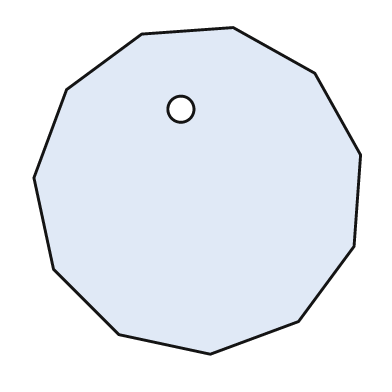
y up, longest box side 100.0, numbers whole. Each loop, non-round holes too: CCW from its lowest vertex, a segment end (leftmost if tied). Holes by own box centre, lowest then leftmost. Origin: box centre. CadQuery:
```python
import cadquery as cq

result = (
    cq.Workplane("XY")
    .moveTo(4.0, -50.0)
    .lineTo(31.0, -40.0)
    .lineTo(48.0, -17.0)
    .lineTo(50.0, 11.0)
    .lineTo(36.0, 36.0)
    .lineTo(11.0, 50.0)
    .lineTo(-17.0, 48.0)
    .lineTo(-40.0, 31.0)
    .lineTo(-50.0, 4.0)
    .lineTo(-44.0, -24.0)
    .lineTo(-24.0, -44.0)
    .close()
    .moveTo(-5.0, 25.0)
    .circle(4.0)
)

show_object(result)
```